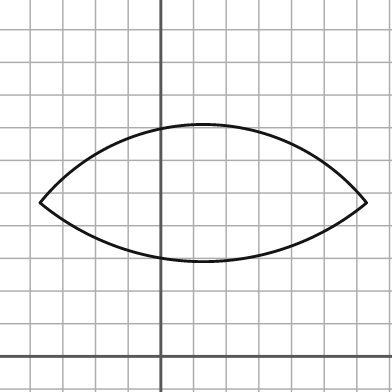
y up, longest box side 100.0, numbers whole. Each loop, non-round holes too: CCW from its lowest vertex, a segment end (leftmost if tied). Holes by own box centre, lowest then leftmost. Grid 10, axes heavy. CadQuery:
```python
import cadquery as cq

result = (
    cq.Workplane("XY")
    .moveTo(-37.0, 47.0)
    .threePointArc((13.0, 29.0), (63.0, 47.0))
    .threePointArc((13.0, 71.0), (-37.0, 47.0))
    .close()
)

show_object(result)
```